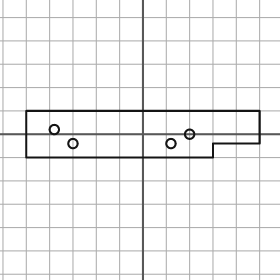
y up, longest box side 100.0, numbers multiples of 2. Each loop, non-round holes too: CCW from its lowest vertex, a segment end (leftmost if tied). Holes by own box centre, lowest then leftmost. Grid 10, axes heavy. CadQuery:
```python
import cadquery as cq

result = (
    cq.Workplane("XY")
    .moveTo(-50.0, -10.0)
    .lineTo(30.0, -10.0)
    .lineTo(30.0, -4.0)
    .lineTo(50.0, -4.0)
    .lineTo(50.0, 10.0)
    .lineTo(-50.0, 10.0)
    .close()
    .moveTo(-30.0, -4.0)
    .circle(2.0)
    .moveTo(12.0, -4.0)
    .circle(2.0)
    .moveTo(20.0, 0.0)
    .circle(2.0)
    .moveTo(-38.0, 2.0)
    .circle(2.0)
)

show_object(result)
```